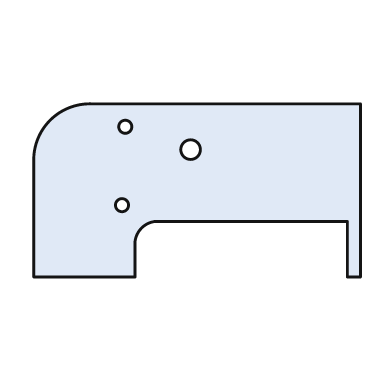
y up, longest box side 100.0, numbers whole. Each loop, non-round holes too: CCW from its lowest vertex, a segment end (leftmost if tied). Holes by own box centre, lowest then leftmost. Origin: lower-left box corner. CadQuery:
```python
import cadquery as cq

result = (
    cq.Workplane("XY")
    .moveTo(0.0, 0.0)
    .lineTo(31.0, 0.0)
    .lineTo(31.0, 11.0)
    .threePointArc((33.0, 15.0), (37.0, 17.0))
    .lineTo(96.0, 17.0)
    .lineTo(96.0, 0.0)
    .lineTo(100.0, 0.0)
    .lineTo(100.0, 53.0)
    .lineTo(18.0, 53.0)
    .threePointArc((5.0, 48.0), (0.0, 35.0))
    .close()
    .moveTo(27.0, 22.0)
    .circle(2.0)
    .moveTo(48.0, 39.0)
    .circle(3.0)
    .moveTo(28.0, 46.0)
    .circle(2.0)
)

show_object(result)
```